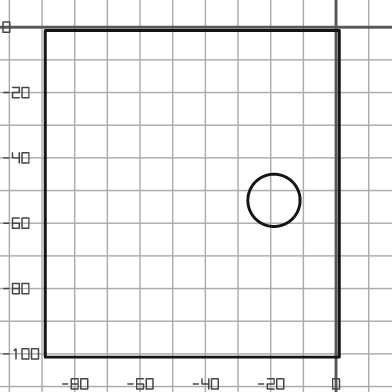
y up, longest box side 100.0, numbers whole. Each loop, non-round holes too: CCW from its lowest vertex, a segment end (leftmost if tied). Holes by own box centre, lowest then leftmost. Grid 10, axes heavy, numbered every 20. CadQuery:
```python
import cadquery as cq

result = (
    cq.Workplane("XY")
    .moveTo(-89.0, -101.0)
    .lineTo(1.0, -101.0)
    .lineTo(1.0, -1.0)
    .lineTo(-89.0, -1.0)
    .close()
    .moveTo(-19.0, -53.0)
    .circle(8.0)
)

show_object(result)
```